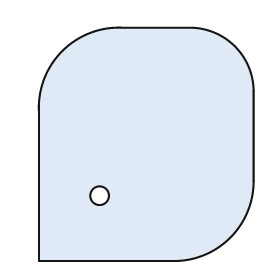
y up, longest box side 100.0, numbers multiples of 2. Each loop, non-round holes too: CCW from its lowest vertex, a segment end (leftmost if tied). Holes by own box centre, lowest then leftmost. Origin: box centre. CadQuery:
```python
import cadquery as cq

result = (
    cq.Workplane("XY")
    .moveTo(-46.0, -50.0)
    .lineTo(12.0, -50.0)
    .threePointArc((36.0, -40.0), (46.0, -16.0))
    .lineTo(46.0, 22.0)
    .threePointArc((38.0, 42.0), (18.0, 50.0))
    .lineTo(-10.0, 50.0)
    .threePointArc((-36.0, 40.0), (-46.0, 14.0))
    .close()
    .moveTo(-20.0, -22.0)
    .circle(4.0)
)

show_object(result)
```